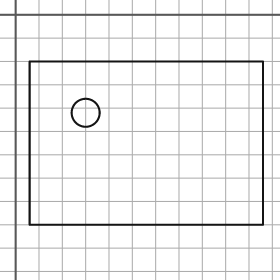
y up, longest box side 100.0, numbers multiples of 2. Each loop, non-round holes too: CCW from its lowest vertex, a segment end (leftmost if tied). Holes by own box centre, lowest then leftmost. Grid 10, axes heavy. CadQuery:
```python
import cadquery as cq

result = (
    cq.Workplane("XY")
    .moveTo(6.0, -90.0)
    .lineTo(106.0, -90.0)
    .lineTo(106.0, -20.0)
    .lineTo(6.0, -20.0)
    .close()
    .moveTo(30.0, -42.0)
    .circle(6.0)
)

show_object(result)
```